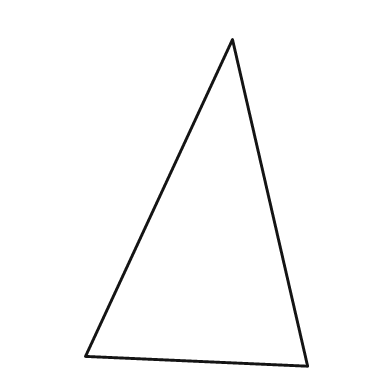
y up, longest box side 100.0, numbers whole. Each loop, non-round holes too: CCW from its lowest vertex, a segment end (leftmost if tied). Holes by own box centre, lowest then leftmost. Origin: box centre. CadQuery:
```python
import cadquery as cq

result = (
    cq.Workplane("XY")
    .moveTo(34.0, -50.0)
    .lineTo(11.0, 50.0)
    .lineTo(-34.0, -47.0)
    .close()
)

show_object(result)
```